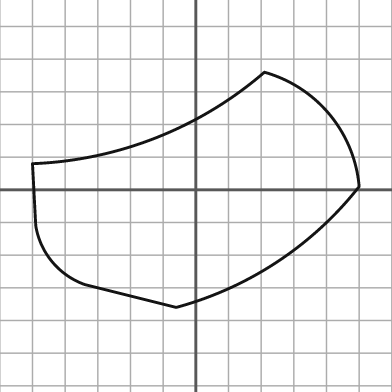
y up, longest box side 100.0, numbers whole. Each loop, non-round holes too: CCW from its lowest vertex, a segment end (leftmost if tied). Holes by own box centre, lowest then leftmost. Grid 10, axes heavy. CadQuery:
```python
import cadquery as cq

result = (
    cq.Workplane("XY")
    .moveTo(-6.0, -36.0)
    .threePointArc((25.0, -22.0), (50.0, 1.0))
    .threePointArc((41.0, 23.0), (21.0, 36.0))
    .threePointArc((-12.0, 16.0), (-50.0, 8.0))
    .lineTo(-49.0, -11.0)
    .threePointArc((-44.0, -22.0), (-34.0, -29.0))
    .close()
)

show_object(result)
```